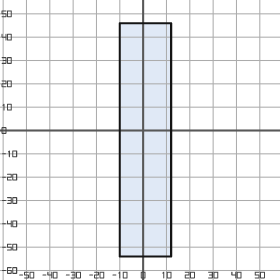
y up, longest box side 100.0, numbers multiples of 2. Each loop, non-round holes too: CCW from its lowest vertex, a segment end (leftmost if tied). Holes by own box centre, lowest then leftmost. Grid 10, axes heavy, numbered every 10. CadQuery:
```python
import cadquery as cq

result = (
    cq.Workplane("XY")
    .moveTo(-10.0, -54.0)
    .lineTo(12.0, -54.0)
    .lineTo(12.0, 46.0)
    .lineTo(-10.0, 46.0)
    .close()
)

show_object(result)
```